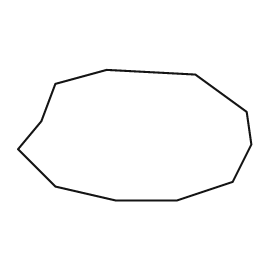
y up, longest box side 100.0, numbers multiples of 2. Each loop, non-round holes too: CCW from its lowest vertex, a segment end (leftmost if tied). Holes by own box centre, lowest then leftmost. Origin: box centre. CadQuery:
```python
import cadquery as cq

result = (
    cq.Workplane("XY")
    .moveTo(-8.0, -28.0)
    .lineTo(18.0, -28.0)
    .lineTo(42.0, -20.0)
    .lineTo(50.0, -4.0)
    .lineTo(48.0, 10.0)
    .lineTo(26.0, 26.0)
    .lineTo(-12.0, 28.0)
    .lineTo(-34.0, 22.0)
    .lineTo(-40.0, 6.0)
    .lineTo(-50.0, -6.0)
    .lineTo(-34.0, -22.0)
    .close()
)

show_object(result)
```